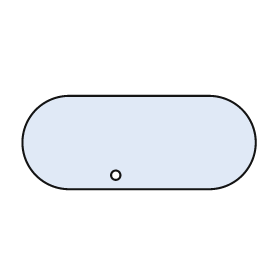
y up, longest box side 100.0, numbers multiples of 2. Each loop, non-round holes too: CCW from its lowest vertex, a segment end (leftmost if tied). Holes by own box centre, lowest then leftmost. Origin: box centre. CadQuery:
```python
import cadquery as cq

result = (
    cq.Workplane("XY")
    .moveTo(-30.0, -20.0)
    .lineTo(30.0, -20.0)
    .threePointArc((50.0, 0.0), (30.0, 20.0))
    .lineTo(-30.0, 20.0)
    .threePointArc((-50.0, 0.0), (-30.0, -20.0))
    .close()
    .moveTo(-10.0, -14.0)
    .circle(2.0)
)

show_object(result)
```